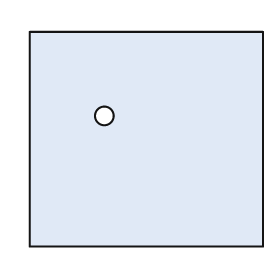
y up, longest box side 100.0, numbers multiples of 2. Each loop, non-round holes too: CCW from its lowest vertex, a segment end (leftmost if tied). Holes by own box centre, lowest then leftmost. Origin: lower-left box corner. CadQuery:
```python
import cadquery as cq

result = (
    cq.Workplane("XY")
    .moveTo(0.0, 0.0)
    .lineTo(100.0, 0.0)
    .lineTo(100.0, 92.0)
    .lineTo(0.0, 92.0)
    .close()
    .moveTo(32.0, 56.0)
    .circle(4.0)
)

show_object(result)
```